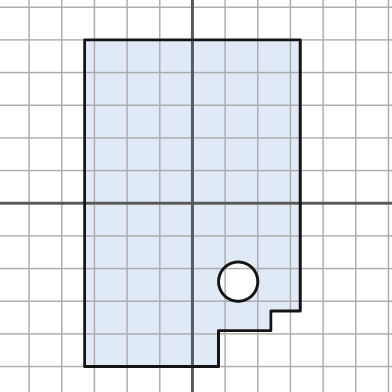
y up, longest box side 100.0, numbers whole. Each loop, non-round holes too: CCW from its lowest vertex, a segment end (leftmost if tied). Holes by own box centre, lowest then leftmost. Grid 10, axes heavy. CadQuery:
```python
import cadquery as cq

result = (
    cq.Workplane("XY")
    .moveTo(-33.0, -50.0)
    .lineTo(8.0, -50.0)
    .lineTo(8.0, -39.0)
    .lineTo(24.0, -39.0)
    .lineTo(24.0, -33.0)
    .lineTo(33.0, -33.0)
    .lineTo(33.0, 50.0)
    .lineTo(-33.0, 50.0)
    .close()
    .moveTo(14.0, -24.0)
    .circle(6.0)
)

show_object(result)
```